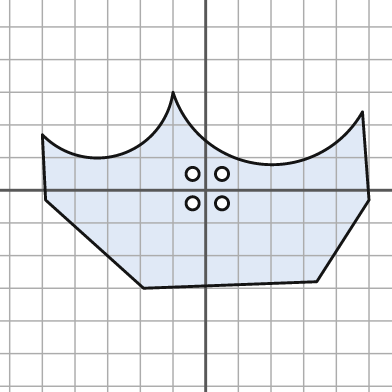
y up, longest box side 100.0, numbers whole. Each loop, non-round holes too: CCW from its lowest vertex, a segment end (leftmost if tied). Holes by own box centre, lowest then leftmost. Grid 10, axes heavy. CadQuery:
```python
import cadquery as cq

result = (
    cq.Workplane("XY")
    .moveTo(-19.0, -30.0)
    .lineTo(34.0, -28.0)
    .lineTo(50.0, -3.0)
    .lineTo(48.0, 24.0)
    .threePointArc((17.0, 8.0), (-10.0, 30.0))
    .threePointArc((-26.0, 11.0), (-50.0, 17.0))
    .lineTo(-49.0, -3.0)
    .close()
    .moveTo(-4.0, -4.0)
    .circle(2.0)
    .moveTo(5.0, -4.0)
    .circle(2.0)
    .moveTo(-4.0, 5.0)
    .circle(2.0)
    .moveTo(5.0, 5.0)
    .circle(2.0)
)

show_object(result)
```